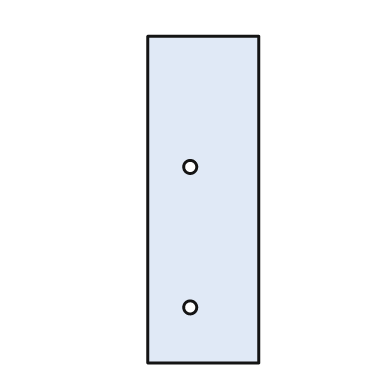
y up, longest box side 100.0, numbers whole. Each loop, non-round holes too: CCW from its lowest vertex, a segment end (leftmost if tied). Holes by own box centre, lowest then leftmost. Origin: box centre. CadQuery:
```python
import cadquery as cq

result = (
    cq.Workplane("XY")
    .moveTo(-17.0, -50.0)
    .lineTo(17.0, -50.0)
    .lineTo(17.0, 50.0)
    .lineTo(-17.0, 50.0)
    .close()
    .moveTo(-4.0, -33.0)
    .circle(2.0)
    .moveTo(-4.0, 10.0)
    .circle(2.0)
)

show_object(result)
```